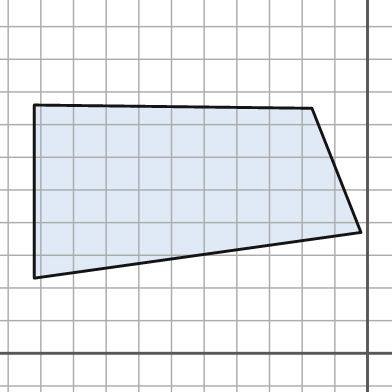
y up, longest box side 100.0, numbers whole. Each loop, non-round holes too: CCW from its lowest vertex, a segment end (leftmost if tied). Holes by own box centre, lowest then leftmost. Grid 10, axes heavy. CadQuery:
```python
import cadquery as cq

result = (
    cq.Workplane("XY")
    .moveTo(-102.0, 23.0)
    .lineTo(-2.0, 37.0)
    .lineTo(-17.0, 75.0)
    .lineTo(-102.0, 76.0)
    .close()
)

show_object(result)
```